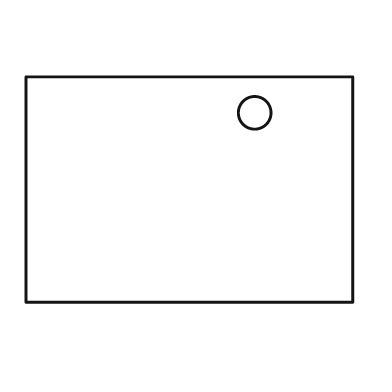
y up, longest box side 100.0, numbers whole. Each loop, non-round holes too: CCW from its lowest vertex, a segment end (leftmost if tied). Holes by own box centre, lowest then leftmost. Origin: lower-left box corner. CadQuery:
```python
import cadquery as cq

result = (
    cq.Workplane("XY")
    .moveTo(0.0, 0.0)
    .lineTo(100.0, 0.0)
    .lineTo(100.0, 69.0)
    .lineTo(0.0, 69.0)
    .close()
    .moveTo(70.0, 58.0)
    .circle(5.0)
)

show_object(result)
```